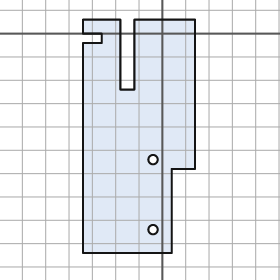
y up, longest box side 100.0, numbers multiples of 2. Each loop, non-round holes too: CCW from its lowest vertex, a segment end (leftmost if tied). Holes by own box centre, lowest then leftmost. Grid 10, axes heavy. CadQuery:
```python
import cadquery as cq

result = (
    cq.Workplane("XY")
    .moveTo(-34.0, -94.0)
    .lineTo(4.0, -94.0)
    .lineTo(4.0, -58.0)
    .lineTo(14.0, -58.0)
    .lineTo(14.0, 6.0)
    .lineTo(-12.0, 6.0)
    .lineTo(-12.0, -24.0)
    .lineTo(-18.0, -24.0)
    .lineTo(-18.0, 6.0)
    .lineTo(-34.0, 6.0)
    .lineTo(-34.0, 0.0)
    .lineTo(-26.0, 0.0)
    .lineTo(-26.0, -4.0)
    .lineTo(-34.0, -4.0)
    .close()
    .moveTo(-4.0, -84.0)
    .circle(2.0)
    .moveTo(-4.0, -54.0)
    .circle(2.0)
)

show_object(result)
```